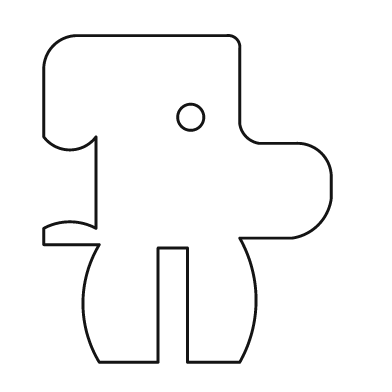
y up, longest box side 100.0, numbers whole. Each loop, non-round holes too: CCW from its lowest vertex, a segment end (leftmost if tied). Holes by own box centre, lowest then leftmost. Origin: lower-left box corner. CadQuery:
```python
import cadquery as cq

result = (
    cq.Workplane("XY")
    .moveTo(17.0, 0.0)
    .lineTo(35.0, 0.0)
    .lineTo(35.0, 35.0)
    .lineTo(44.0, 35.0)
    .lineTo(44.0, 0.0)
    .lineTo(60.0, 0.0)
    .threePointArc((65.0, 19.0), (60.0, 38.0))
    .lineTo(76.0, 38.0)
    .threePointArc((84.0, 42.0), (88.0, 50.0))
    .lineTo(88.0, 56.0)
    .threePointArc((85.0, 64.0), (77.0, 67.0))
    .lineTo(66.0, 67.0)
    .threePointArc((62.0, 69.0), (60.0, 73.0))
    .lineTo(60.0, 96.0)
    .threePointArc((59.0, 99.0), (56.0, 100.0))
    .lineTo(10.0, 100.0)
    .threePointArc((3.0, 97.0), (0.0, 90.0))
    .lineTo(0.0, 69.0)
    .threePointArc((8.0, 65.0), (16.0, 69.0))
    .lineTo(16.0, 41.0)
    .threePointArc((8.0, 43.0), (0.0, 41.0))
    .lineTo(0.0, 36.0)
    .lineTo(17.0, 36.0)
    .threePointArc((12.0, 18.0), (17.0, 0.0))
    .close()
    .moveTo(45.0, 75.0)
    .circle(4.0)
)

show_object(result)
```